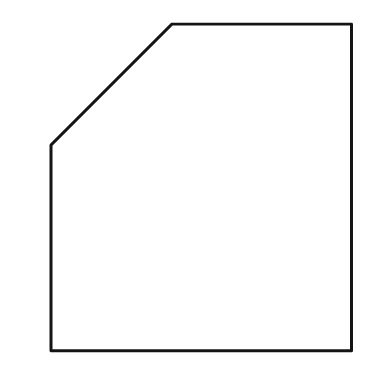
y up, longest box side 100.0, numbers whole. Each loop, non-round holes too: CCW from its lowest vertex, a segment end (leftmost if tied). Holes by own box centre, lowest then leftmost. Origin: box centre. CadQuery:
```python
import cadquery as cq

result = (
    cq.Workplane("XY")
    .moveTo(-46.0, -50.0)
    .lineTo(46.0, -50.0)
    .lineTo(46.0, 50.0)
    .lineTo(-9.0, 50.0)
    .lineTo(-46.0, 13.0)
    .close()
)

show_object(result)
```